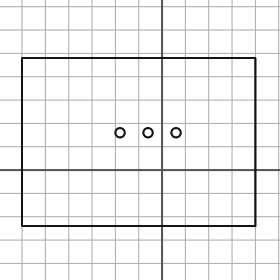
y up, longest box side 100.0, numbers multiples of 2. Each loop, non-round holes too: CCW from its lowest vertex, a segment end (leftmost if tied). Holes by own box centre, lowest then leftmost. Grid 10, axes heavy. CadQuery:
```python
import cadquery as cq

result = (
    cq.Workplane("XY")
    .moveTo(-60.0, -24.0)
    .lineTo(40.0, -24.0)
    .lineTo(40.0, 48.0)
    .lineTo(-60.0, 48.0)
    .close()
    .moveTo(-18.0, 16.0)
    .circle(2.0)
    .moveTo(-6.0, 16.0)
    .circle(2.0)
    .moveTo(6.0, 16.0)
    .circle(2.0)
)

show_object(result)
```